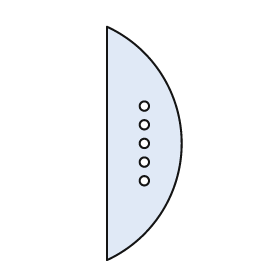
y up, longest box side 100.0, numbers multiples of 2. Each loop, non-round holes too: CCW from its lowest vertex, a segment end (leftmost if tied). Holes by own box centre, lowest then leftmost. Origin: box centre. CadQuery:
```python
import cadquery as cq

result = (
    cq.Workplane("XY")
    .moveTo(-16.0, -50.0)
    .threePointArc((16.0, 0.0), (-16.0, 50.0))
    .close()
    .moveTo(0.0, -16.0)
    .circle(2.0)
    .moveTo(0.0, -8.0)
    .circle(2.0)
    .moveTo(0.0, 0.0)
    .circle(2.0)
    .moveTo(0.0, 8.0)
    .circle(2.0)
    .moveTo(0.0, 16.0)
    .circle(2.0)
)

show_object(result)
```